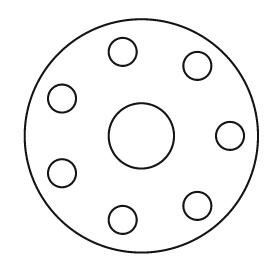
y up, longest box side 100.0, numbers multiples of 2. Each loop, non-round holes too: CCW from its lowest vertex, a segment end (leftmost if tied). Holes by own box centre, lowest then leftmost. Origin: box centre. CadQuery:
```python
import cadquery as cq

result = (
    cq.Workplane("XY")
    .moveTo(0.0, 0.0)
    .circle(50.0)
    .moveTo(-8.0, -36.0)
    .circle(6.0)
    .moveTo(24.0, -30.0)
    .circle(6.0)
    .moveTo(-34.0, -16.0)
    .circle(6.0)
    .moveTo(0.0, 0.0)
    .circle(14.0)
    .moveTo(38.0, 0.0)
    .circle(6.0)
    .moveTo(-34.0, 16.0)
    .circle(6.0)
    .moveTo(24.0, 30.0)
    .circle(6.0)
    .moveTo(-8.0, 36.0)
    .circle(6.0)
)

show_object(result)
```